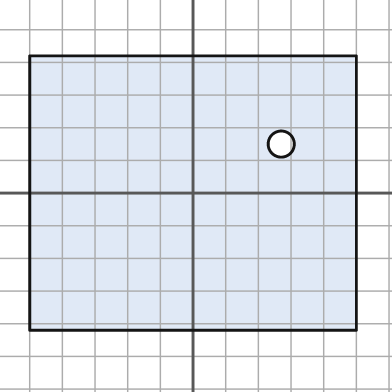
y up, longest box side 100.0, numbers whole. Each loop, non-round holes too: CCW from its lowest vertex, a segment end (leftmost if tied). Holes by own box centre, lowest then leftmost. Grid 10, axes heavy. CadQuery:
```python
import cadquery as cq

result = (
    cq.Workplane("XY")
    .moveTo(-50.0, -42.0)
    .lineTo(50.0, -42.0)
    .lineTo(50.0, 42.0)
    .lineTo(-50.0, 42.0)
    .close()
    .moveTo(27.0, 15.0)
    .circle(4.0)
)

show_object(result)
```